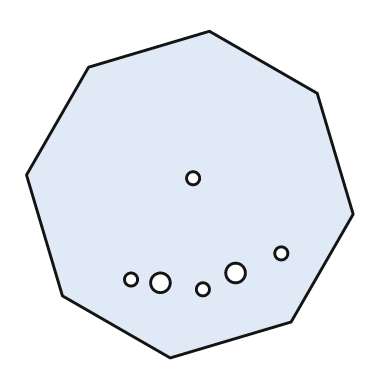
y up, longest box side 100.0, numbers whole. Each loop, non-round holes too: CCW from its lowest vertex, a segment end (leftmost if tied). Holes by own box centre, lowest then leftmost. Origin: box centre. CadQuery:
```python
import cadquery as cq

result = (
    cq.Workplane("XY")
    .moveTo(-6.0, -50.0)
    .lineTo(31.0, -39.0)
    .lineTo(50.0, -6.0)
    .lineTo(39.0, 31.0)
    .lineTo(6.0, 50.0)
    .lineTo(-31.0, 39.0)
    .lineTo(-50.0, 6.0)
    .lineTo(-39.0, -31.0)
    .close()
    .moveTo(4.0, -29.0)
    .circle(2.0)
    .moveTo(-9.0, -27.0)
    .circle(3.0)
    .moveTo(-18.0, -26.0)
    .circle(2.0)
    .moveTo(14.0, -24.0)
    .circle(3.0)
    .moveTo(28.0, -18.0)
    .circle(2.0)
    .moveTo(1.0, 5.0)
    .circle(2.0)
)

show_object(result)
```